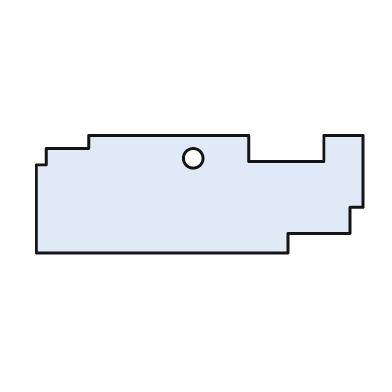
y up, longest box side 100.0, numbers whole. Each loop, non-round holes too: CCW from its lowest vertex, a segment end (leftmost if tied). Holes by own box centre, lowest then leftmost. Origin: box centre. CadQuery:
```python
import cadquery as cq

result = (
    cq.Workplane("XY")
    .moveTo(-50.0, -18.0)
    .lineTo(27.0, -18.0)
    .lineTo(27.0, -12.0)
    .lineTo(46.0, -12.0)
    .lineTo(46.0, -4.0)
    .lineTo(50.0, -4.0)
    .lineTo(50.0, 18.0)
    .lineTo(38.0, 18.0)
    .lineTo(38.0, 10.0)
    .lineTo(15.0, 10.0)
    .lineTo(15.0, 18.0)
    .lineTo(-34.0, 18.0)
    .lineTo(-34.0, 14.0)
    .lineTo(-47.0, 14.0)
    .lineTo(-47.0, 9.0)
    .lineTo(-50.0, 9.0)
    .close()
    .moveTo(-2.0, 11.0)
    .circle(3.0)
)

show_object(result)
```